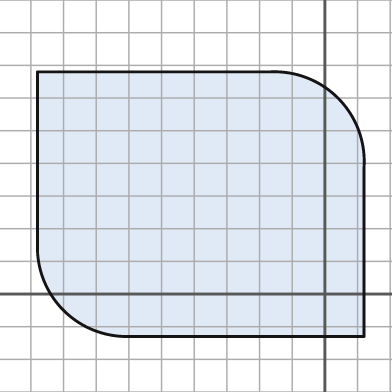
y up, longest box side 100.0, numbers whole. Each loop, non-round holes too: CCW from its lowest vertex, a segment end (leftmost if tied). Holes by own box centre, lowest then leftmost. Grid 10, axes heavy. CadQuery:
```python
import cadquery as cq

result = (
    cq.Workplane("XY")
    .moveTo(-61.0, -13.0)
    .lineTo(12.0, -13.0)
    .lineTo(12.0, 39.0)
    .threePointArc((4.0, 60.0), (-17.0, 68.0))
    .lineTo(-88.0, 68.0)
    .lineTo(-88.0, 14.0)
    .threePointArc((-80.0, -5.0), (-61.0, -13.0))
    .close()
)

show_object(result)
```